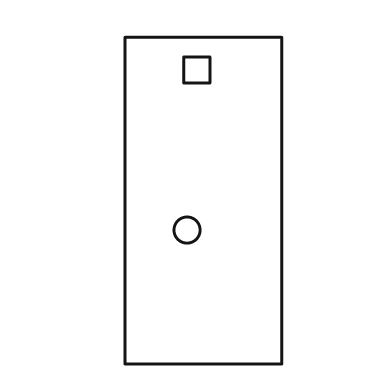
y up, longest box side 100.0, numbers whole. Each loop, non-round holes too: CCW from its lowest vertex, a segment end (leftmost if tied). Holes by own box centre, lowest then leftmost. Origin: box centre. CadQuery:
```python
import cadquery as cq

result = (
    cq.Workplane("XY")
    .moveTo(-24.0, -50.0)
    .lineTo(24.0, -50.0)
    .lineTo(24.0, 50.0)
    .lineTo(-24.0, 50.0)
    .close()
    .moveTo(-5.0, -9.0)
    .circle(4.0)
    .moveTo(-6.0, 36.0)
    .lineTo(2.0, 36.0)
    .lineTo(2.0, 44.0)
    .lineTo(-6.0, 44.0)
    .close()
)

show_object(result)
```